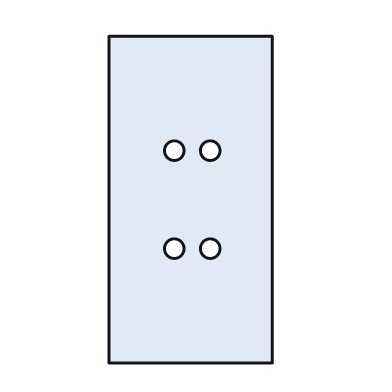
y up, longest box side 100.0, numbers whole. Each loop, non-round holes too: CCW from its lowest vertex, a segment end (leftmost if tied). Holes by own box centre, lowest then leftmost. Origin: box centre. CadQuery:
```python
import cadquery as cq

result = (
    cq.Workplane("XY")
    .moveTo(-25.0, -50.0)
    .lineTo(25.0, -50.0)
    .lineTo(25.0, 50.0)
    .lineTo(-25.0, 50.0)
    .close()
    .moveTo(-5.0, -15.0)
    .circle(3.0)
    .moveTo(6.0, -15.0)
    .circle(3.0)
    .moveTo(-5.0, 15.0)
    .circle(3.0)
    .moveTo(6.0, 15.0)
    .circle(3.0)
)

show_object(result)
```